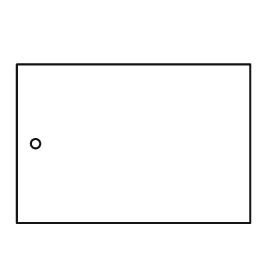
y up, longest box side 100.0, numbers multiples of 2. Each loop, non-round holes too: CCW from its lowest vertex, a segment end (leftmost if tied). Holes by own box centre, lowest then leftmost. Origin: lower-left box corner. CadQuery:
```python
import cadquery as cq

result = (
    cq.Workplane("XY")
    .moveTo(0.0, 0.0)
    .lineTo(100.0, 0.0)
    .lineTo(100.0, 68.0)
    .lineTo(0.0, 68.0)
    .close()
    .moveTo(8.0, 34.0)
    .circle(2.0)
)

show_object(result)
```